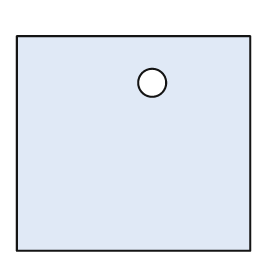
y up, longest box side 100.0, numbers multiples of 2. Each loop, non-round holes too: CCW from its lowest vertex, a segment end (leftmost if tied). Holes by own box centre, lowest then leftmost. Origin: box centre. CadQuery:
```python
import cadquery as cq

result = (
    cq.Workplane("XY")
    .moveTo(-50.0, -46.0)
    .lineTo(50.0, -46.0)
    .lineTo(50.0, 46.0)
    .lineTo(-50.0, 46.0)
    .close()
    .moveTo(8.0, 26.0)
    .circle(6.0)
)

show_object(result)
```